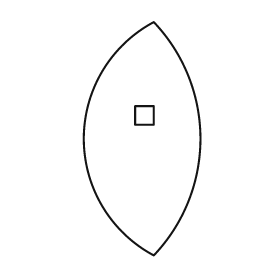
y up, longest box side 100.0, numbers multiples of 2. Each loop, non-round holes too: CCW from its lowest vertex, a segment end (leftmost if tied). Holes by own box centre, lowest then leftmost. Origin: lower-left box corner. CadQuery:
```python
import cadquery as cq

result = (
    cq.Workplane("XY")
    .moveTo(30.0, 0.0)
    .threePointArc((50.0, 50.0), (30.0, 100.0))
    .threePointArc((0.0, 50.0), (30.0, 0.0))
    .close()
    .moveTo(22.0, 56.0)
    .lineTo(30.0, 56.0)
    .lineTo(30.0, 64.0)
    .lineTo(22.0, 64.0)
    .close()
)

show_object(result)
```